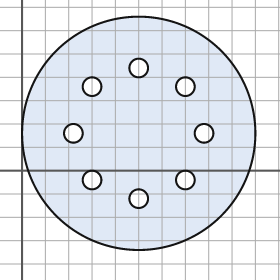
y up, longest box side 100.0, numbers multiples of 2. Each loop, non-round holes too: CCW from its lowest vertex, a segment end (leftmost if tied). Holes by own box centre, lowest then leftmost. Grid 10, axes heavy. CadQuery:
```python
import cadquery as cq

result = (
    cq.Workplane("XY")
    .moveTo(50.0, 16.0)
    .circle(50.0)
    .moveTo(50.0, -12.0)
    .circle(4.0)
    .moveTo(30.0, -4.0)
    .circle(4.0)
    .moveTo(70.0, -4.0)
    .circle(4.0)
    .moveTo(22.0, 16.0)
    .circle(4.0)
    .moveTo(78.0, 16.0)
    .circle(4.0)
    .moveTo(30.0, 36.0)
    .circle(4.0)
    .moveTo(70.0, 36.0)
    .circle(4.0)
    .moveTo(50.0, 44.0)
    .circle(4.0)
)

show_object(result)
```